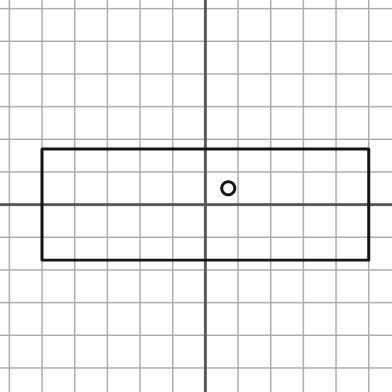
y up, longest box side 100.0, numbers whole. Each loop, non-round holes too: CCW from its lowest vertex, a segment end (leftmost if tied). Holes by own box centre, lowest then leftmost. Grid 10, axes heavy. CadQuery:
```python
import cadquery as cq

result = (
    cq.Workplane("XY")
    .moveTo(-50.0, -17.0)
    .lineTo(50.0, -17.0)
    .lineTo(50.0, 17.0)
    .lineTo(-50.0, 17.0)
    .close()
    .moveTo(7.0, 5.0)
    .circle(2.0)
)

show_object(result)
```